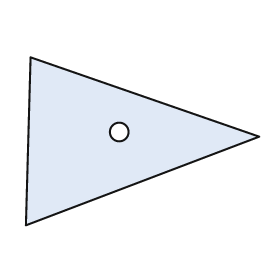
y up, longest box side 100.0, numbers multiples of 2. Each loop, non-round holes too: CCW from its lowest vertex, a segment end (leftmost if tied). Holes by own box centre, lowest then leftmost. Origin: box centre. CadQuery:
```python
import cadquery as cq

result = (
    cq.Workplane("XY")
    .moveTo(-50.0, -36.0)
    .lineTo(50.0, 2.0)
    .lineTo(-48.0, 36.0)
    .close()
    .moveTo(-10.0, 4.0)
    .circle(4.0)
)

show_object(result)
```